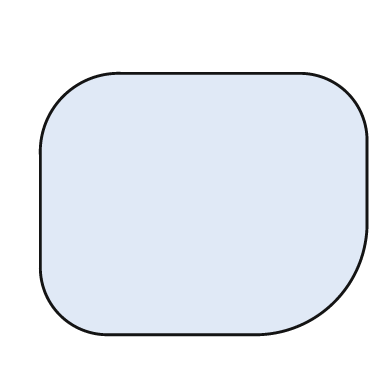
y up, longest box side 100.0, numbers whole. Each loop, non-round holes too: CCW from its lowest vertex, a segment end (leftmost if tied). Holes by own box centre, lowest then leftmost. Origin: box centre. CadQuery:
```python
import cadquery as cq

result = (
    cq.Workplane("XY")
    .moveTo(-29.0, -40.0)
    .lineTo(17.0, -40.0)
    .threePointArc((40.0, -30.0), (50.0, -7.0))
    .lineTo(50.0, 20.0)
    .threePointArc((44.0, 34.0), (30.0, 40.0))
    .lineTo(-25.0, 40.0)
    .threePointArc((-43.0, 33.0), (-50.0, 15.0))
    .lineTo(-50.0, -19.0)
    .threePointArc((-44.0, -34.0), (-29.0, -40.0))
    .close()
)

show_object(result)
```